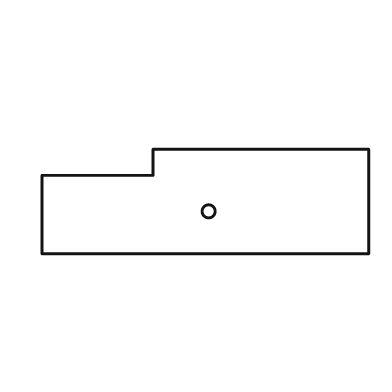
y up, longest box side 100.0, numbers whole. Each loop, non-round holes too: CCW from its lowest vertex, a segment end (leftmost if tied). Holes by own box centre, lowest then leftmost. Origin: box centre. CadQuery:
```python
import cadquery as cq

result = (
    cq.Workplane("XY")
    .moveTo(-50.0, -16.0)
    .lineTo(50.0, -16.0)
    .lineTo(50.0, 16.0)
    .lineTo(-16.0, 16.0)
    .lineTo(-16.0, 8.0)
    .lineTo(-50.0, 8.0)
    .close()
    .moveTo(1.0, -3.0)
    .circle(2.0)
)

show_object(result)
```